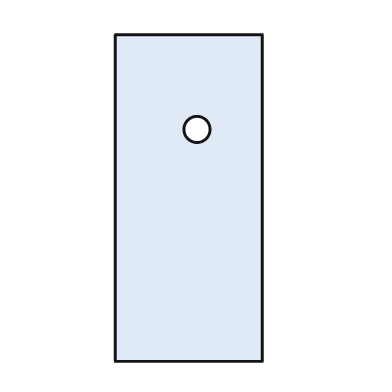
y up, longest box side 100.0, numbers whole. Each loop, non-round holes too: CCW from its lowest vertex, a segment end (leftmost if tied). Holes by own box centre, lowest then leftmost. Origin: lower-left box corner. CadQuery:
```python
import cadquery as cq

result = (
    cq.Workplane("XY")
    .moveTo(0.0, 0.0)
    .lineTo(45.0, 0.0)
    .lineTo(45.0, 100.0)
    .lineTo(0.0, 100.0)
    .close()
    .moveTo(25.0, 71.0)
    .circle(4.0)
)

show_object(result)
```